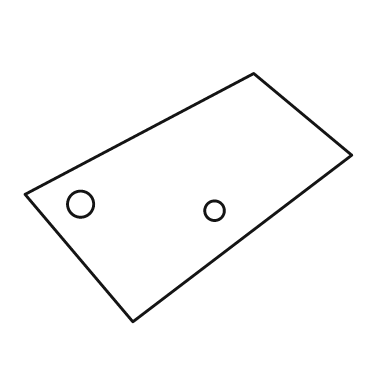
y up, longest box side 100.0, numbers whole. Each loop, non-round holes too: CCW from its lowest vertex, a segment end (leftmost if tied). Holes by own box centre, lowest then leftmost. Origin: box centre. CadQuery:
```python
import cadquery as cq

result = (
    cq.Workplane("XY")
    .moveTo(-17.0, -38.0)
    .lineTo(50.0, 13.0)
    .lineTo(20.0, 38.0)
    .lineTo(-50.0, 1.0)
    .close()
    .moveTo(8.0, -4.0)
    .circle(3.0)
    .moveTo(-33.0, -2.0)
    .circle(4.0)
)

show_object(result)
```